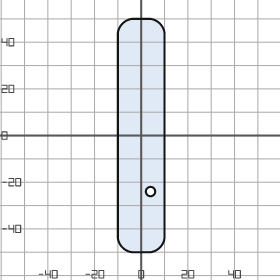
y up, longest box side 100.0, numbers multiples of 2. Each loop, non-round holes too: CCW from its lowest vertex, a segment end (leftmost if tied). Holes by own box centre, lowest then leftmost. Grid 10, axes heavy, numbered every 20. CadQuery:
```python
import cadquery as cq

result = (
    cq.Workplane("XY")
    .moveTo(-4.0, -50.0)
    .lineTo(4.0, -50.0)
    .threePointArc((8.0, -48.0), (10.0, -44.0))
    .lineTo(10.0, 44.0)
    .threePointArc((8.0, 48.0), (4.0, 50.0))
    .lineTo(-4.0, 50.0)
    .threePointArc((-8.0, 48.0), (-10.0, 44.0))
    .lineTo(-10.0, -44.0)
    .threePointArc((-8.0, -48.0), (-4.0, -50.0))
    .close()
    .moveTo(4.0, -24.0)
    .circle(2.0)
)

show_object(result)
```